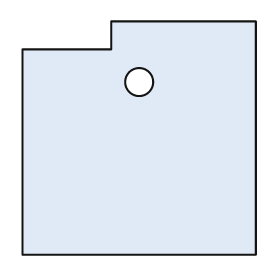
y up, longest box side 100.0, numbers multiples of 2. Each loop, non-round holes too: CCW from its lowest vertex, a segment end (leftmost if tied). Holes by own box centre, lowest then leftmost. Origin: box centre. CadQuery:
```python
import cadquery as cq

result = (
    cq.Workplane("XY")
    .moveTo(-50.0, -50.0)
    .lineTo(50.0, -50.0)
    .lineTo(50.0, 50.0)
    .lineTo(-12.0, 50.0)
    .lineTo(-12.0, 38.0)
    .lineTo(-50.0, 38.0)
    .close()
    .moveTo(0.0, 24.0)
    .circle(6.0)
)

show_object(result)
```